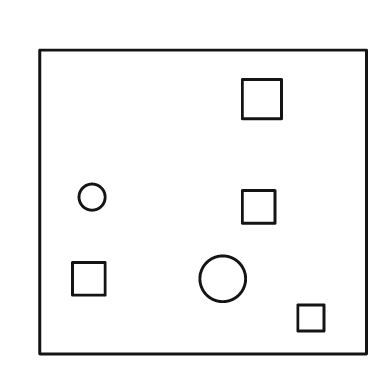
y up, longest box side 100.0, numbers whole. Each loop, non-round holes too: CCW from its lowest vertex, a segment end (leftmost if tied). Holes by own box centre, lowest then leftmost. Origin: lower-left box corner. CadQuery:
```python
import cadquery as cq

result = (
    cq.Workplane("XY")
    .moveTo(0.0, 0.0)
    .lineTo(100.0, 0.0)
    .lineTo(100.0, 93.0)
    .lineTo(0.0, 93.0)
    .close()
    .moveTo(79.0, 7.0)
    .lineTo(87.0, 7.0)
    .lineTo(87.0, 15.0)
    .lineTo(79.0, 15.0)
    .close()
    .moveTo(10.0, 18.0)
    .lineTo(20.0, 18.0)
    .lineTo(20.0, 28.0)
    .lineTo(10.0, 28.0)
    .close()
    .moveTo(56.0, 23.0)
    .circle(7.0)
    .moveTo(62.0, 40.0)
    .lineTo(72.0, 40.0)
    .lineTo(72.0, 50.0)
    .lineTo(62.0, 50.0)
    .close()
    .moveTo(16.0, 48.0)
    .circle(4.0)
    .moveTo(62.0, 72.0)
    .lineTo(74.0, 72.0)
    .lineTo(74.0, 84.0)
    .lineTo(62.0, 84.0)
    .close()
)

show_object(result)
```